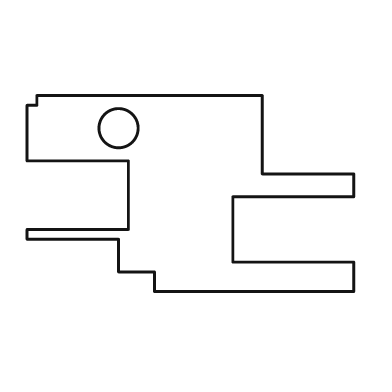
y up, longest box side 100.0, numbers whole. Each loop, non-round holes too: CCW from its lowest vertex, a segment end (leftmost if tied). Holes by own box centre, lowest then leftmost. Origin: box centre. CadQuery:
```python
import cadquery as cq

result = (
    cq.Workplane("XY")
    .moveTo(-11.0, -30.0)
    .lineTo(50.0, -30.0)
    .lineTo(50.0, -21.0)
    .lineTo(13.0, -21.0)
    .lineTo(13.0, -1.0)
    .lineTo(50.0, -1.0)
    .lineTo(50.0, 6.0)
    .lineTo(22.0, 6.0)
    .lineTo(22.0, 30.0)
    .lineTo(-47.0, 30.0)
    .lineTo(-47.0, 27.0)
    .lineTo(-50.0, 27.0)
    .lineTo(-50.0, 10.0)
    .lineTo(-19.0, 10.0)
    .lineTo(-19.0, -11.0)
    .lineTo(-50.0, -11.0)
    .lineTo(-50.0, -14.0)
    .lineTo(-22.0, -14.0)
    .lineTo(-22.0, -24.0)
    .lineTo(-11.0, -24.0)
    .close()
    .moveTo(-22.0, 20.0)
    .circle(6.0)
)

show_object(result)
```